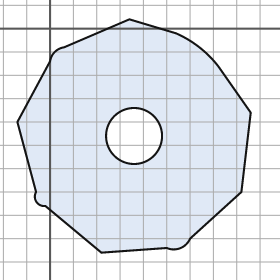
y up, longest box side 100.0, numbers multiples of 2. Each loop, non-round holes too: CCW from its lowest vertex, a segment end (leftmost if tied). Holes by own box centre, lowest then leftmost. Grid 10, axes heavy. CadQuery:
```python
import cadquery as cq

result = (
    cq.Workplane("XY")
    .moveTo(22.0, -96.0)
    .lineTo(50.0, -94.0)
    .threePointArc((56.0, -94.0), (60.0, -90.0))
    .lineTo(82.0, -70.0)
    .lineTo(86.0, -36.0)
    .lineTo(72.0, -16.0)
    .threePointArc((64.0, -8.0), (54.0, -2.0))
    .lineTo(34.0, 4.0)
    .lineTo(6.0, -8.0)
    .threePointArc((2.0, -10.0), (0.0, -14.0))
    .lineTo(-14.0, -40.0)
    .lineTo(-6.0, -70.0)
    .threePointArc((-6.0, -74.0), (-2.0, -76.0))
    .close()
    .moveTo(36.0, -46.0)
    .circle(12.0)
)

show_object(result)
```